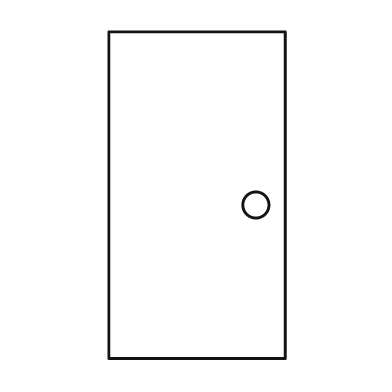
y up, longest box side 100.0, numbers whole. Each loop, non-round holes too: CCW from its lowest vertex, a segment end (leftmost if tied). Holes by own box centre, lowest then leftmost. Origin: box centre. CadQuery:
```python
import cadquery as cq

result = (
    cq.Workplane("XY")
    .moveTo(-27.0, -50.0)
    .lineTo(27.0, -50.0)
    .lineTo(27.0, 50.0)
    .lineTo(-27.0, 50.0)
    .close()
    .moveTo(18.0, -3.0)
    .circle(4.0)
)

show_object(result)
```